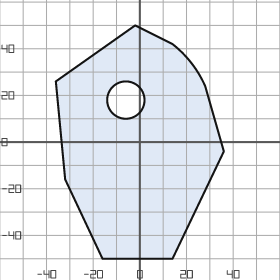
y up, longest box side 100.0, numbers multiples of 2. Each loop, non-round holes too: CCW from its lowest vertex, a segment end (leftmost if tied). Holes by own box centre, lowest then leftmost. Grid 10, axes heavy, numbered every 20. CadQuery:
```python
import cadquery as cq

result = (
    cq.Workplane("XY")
    .moveTo(-16.0, -50.0)
    .lineTo(14.0, -50.0)
    .lineTo(36.0, -4.0)
    .lineTo(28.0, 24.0)
    .threePointArc((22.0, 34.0), (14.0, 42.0))
    .lineTo(-2.0, 50.0)
    .lineTo(-36.0, 26.0)
    .lineTo(-32.0, -16.0)
    .close()
    .moveTo(-6.0, 18.0)
    .circle(8.0)
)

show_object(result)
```